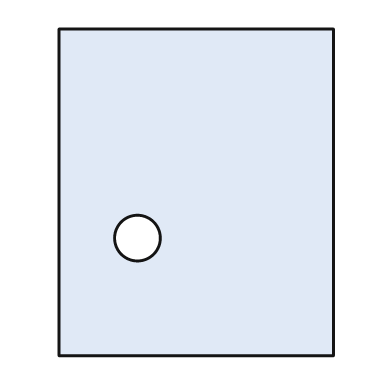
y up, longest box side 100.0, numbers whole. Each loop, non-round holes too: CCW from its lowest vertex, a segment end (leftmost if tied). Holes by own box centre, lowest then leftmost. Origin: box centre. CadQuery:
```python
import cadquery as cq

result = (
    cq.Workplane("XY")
    .moveTo(-42.0, -50.0)
    .lineTo(42.0, -50.0)
    .lineTo(42.0, 50.0)
    .lineTo(-42.0, 50.0)
    .close()
    .moveTo(-18.0, -14.0)
    .circle(7.0)
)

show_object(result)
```